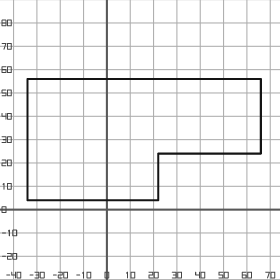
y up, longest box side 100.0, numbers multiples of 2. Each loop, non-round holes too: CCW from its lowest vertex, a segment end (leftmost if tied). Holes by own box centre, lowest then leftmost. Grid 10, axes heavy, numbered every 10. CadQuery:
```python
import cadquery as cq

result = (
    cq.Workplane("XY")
    .moveTo(-34.0, 4.0)
    .lineTo(22.0, 4.0)
    .lineTo(22.0, 24.0)
    .lineTo(66.0, 24.0)
    .lineTo(66.0, 56.0)
    .lineTo(-34.0, 56.0)
    .close()
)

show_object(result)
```